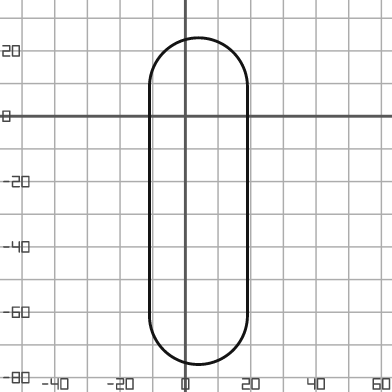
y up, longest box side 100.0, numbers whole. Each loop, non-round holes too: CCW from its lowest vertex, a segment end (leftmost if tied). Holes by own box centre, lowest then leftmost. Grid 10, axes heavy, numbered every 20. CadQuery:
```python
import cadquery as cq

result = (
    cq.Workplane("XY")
    .moveTo(-11.0, -61.0)
    .threePointArc((4.0, -76.0), (19.0, -61.0))
    .lineTo(19.0, 9.0)
    .threePointArc((4.0, 24.0), (-11.0, 9.0))
    .close()
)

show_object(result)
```